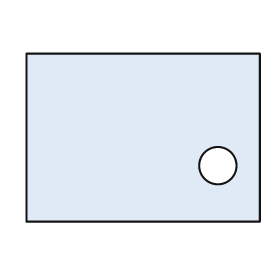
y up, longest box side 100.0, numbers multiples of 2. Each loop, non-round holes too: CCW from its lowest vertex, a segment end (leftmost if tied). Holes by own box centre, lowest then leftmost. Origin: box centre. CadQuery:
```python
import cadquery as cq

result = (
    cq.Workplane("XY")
    .moveTo(-50.0, -36.0)
    .lineTo(50.0, -36.0)
    .lineTo(50.0, 36.0)
    .lineTo(-50.0, 36.0)
    .close()
    .moveTo(32.0, -12.0)
    .circle(8.0)
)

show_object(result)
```